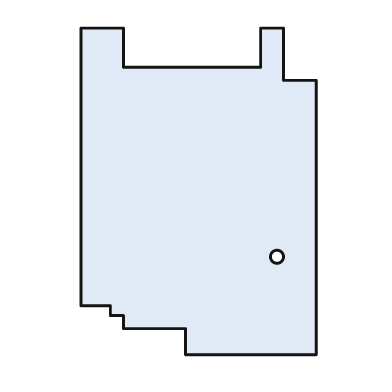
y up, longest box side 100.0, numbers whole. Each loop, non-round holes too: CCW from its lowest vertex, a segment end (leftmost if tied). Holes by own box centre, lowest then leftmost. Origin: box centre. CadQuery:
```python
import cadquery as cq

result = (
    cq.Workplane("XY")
    .moveTo(-4.0, -50.0)
    .lineTo(36.0, -50.0)
    .lineTo(36.0, 34.0)
    .lineTo(26.0, 34.0)
    .lineTo(26.0, 50.0)
    .lineTo(19.0, 50.0)
    .lineTo(19.0, 38.0)
    .lineTo(-23.0, 38.0)
    .lineTo(-23.0, 50.0)
    .lineTo(-36.0, 50.0)
    .lineTo(-36.0, -35.0)
    .lineTo(-27.0, -35.0)
    .lineTo(-27.0, -38.0)
    .lineTo(-23.0, -38.0)
    .lineTo(-23.0, -42.0)
    .lineTo(-4.0, -42.0)
    .close()
    .moveTo(24.0, -20.0)
    .circle(2.0)
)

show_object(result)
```